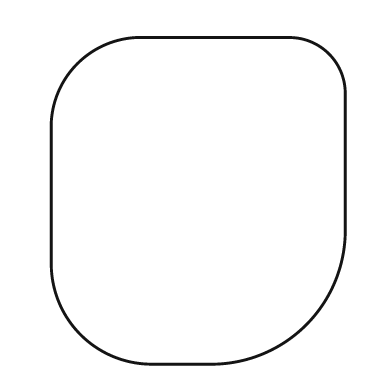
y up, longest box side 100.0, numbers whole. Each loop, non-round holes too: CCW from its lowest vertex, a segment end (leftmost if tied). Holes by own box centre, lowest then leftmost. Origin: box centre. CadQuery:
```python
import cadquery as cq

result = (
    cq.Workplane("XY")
    .moveTo(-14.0, -50.0)
    .lineTo(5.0, -50.0)
    .threePointArc((33.0, -38.0), (45.0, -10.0))
    .lineTo(45.0, 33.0)
    .threePointArc((40.0, 45.0), (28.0, 50.0))
    .lineTo(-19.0, 50.0)
    .threePointArc((-37.0, 42.0), (-45.0, 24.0))
    .lineTo(-45.0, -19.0)
    .threePointArc((-36.0, -41.0), (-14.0, -50.0))
    .close()
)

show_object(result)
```